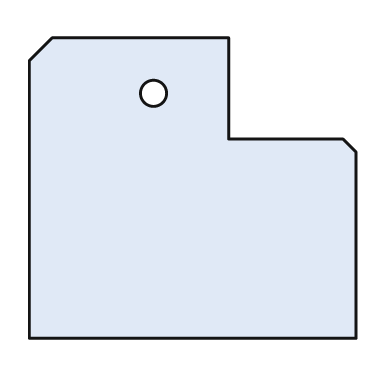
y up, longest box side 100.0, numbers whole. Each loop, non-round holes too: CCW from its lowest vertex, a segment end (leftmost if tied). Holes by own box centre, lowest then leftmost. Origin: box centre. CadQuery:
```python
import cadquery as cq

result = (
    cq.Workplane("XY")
    .moveTo(-50.0, -46.0)
    .lineTo(50.0, -46.0)
    .lineTo(50.0, 11.0)
    .lineTo(46.0, 15.0)
    .lineTo(11.0, 15.0)
    .lineTo(11.0, 46.0)
    .lineTo(-43.0, 46.0)
    .lineTo(-50.0, 39.0)
    .close()
    .moveTo(-12.0, 29.0)
    .circle(4.0)
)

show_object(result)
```